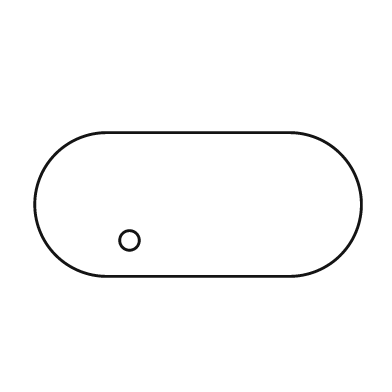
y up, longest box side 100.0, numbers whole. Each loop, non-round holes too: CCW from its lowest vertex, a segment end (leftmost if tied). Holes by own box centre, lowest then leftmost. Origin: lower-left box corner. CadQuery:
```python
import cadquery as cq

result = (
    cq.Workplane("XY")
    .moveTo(22.0, 0.0)
    .lineTo(78.0, 0.0)
    .threePointArc((100.0, 22.0), (78.0, 44.0))
    .lineTo(22.0, 44.0)
    .threePointArc((0.0, 22.0), (22.0, 0.0))
    .close()
    .moveTo(29.0, 11.0)
    .circle(3.0)
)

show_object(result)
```